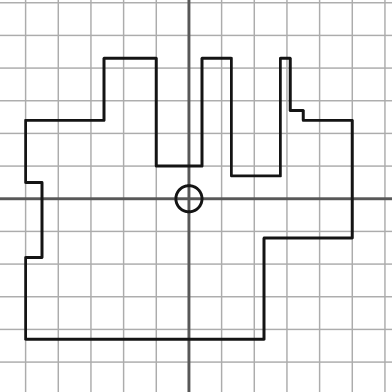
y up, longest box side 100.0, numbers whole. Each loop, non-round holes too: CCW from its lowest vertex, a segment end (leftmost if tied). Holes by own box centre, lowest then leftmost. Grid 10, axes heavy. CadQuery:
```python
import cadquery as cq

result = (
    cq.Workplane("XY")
    .moveTo(-50.0, -43.0)
    .lineTo(23.0, -43.0)
    .lineTo(23.0, -12.0)
    .lineTo(50.0, -12.0)
    .lineTo(50.0, 24.0)
    .lineTo(35.0, 24.0)
    .lineTo(35.0, 27.0)
    .lineTo(31.0, 27.0)
    .lineTo(31.0, 43.0)
    .lineTo(28.0, 43.0)
    .lineTo(28.0, 7.0)
    .lineTo(13.0, 7.0)
    .lineTo(13.0, 43.0)
    .lineTo(4.0, 43.0)
    .lineTo(4.0, 10.0)
    .lineTo(-10.0, 10.0)
    .lineTo(-10.0, 43.0)
    .lineTo(-26.0, 43.0)
    .lineTo(-26.0, 24.0)
    .lineTo(-50.0, 24.0)
    .lineTo(-50.0, 5.0)
    .lineTo(-45.0, 5.0)
    .lineTo(-45.0, -18.0)
    .lineTo(-50.0, -18.0)
    .close()
    .moveTo(0.0, 0.0)
    .circle(4.0)
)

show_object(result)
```